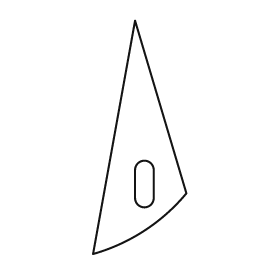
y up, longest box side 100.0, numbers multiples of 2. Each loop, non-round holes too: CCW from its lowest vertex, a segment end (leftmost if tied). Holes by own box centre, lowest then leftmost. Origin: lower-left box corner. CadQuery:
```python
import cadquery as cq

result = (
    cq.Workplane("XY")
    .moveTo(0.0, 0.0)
    .threePointArc((22.0, 10.0), (40.0, 26.0))
    .lineTo(18.0, 100.0)
    .close()
    .moveTo(18.0, 24.0)
    .threePointArc((22.0, 20.0), (26.0, 24.0))
    .lineTo(26.0, 36.0)
    .threePointArc((22.0, 40.0), (18.0, 36.0))
    .close()
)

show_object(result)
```